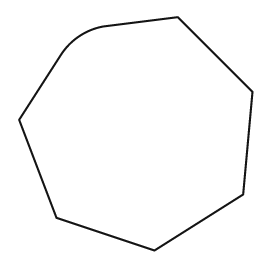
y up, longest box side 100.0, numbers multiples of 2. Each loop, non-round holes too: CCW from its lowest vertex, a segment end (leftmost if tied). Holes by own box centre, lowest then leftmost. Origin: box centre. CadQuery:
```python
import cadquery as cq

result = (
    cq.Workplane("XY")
    .moveTo(8.0, -50.0)
    .lineTo(46.0, -26.0)
    .lineTo(50.0, 18.0)
    .lineTo(18.0, 50.0)
    .lineTo(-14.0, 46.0)
    .threePointArc((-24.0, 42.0), (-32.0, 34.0))
    .lineTo(-50.0, 6.0)
    .lineTo(-34.0, -36.0)
    .close()
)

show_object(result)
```